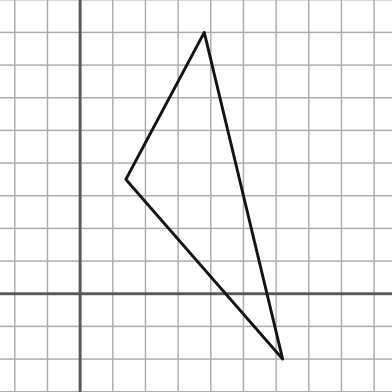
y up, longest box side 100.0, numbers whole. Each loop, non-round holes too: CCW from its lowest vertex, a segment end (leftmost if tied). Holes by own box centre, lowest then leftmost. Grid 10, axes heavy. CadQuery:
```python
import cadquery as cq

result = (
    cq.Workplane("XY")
    .moveTo(62.0, -20.0)
    .lineTo(38.0, 80.0)
    .lineTo(14.0, 35.0)
    .close()
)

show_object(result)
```